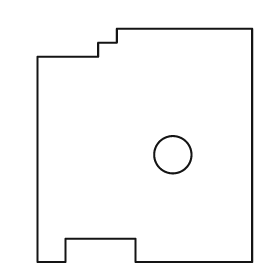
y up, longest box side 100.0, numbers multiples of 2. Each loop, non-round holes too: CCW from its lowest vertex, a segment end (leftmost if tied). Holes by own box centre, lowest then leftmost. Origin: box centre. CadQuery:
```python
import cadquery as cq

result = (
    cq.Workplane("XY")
    .moveTo(-46.0, -50.0)
    .lineTo(-34.0, -50.0)
    .lineTo(-34.0, -40.0)
    .lineTo(-4.0, -40.0)
    .lineTo(-4.0, -50.0)
    .lineTo(46.0, -50.0)
    .lineTo(46.0, 50.0)
    .lineTo(-12.0, 50.0)
    .lineTo(-12.0, 44.0)
    .lineTo(-20.0, 44.0)
    .lineTo(-20.0, 38.0)
    .lineTo(-46.0, 38.0)
    .close()
    .moveTo(12.0, -4.0)
    .circle(8.0)
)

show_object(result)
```